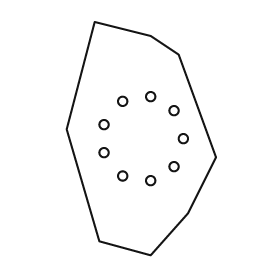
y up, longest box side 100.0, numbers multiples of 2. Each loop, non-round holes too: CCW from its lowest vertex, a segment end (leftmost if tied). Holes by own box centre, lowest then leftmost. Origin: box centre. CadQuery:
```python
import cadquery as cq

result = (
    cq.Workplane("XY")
    .moveTo(4.0, -50.0)
    .lineTo(20.0, -32.0)
    .lineTo(32.0, -8.0)
    .lineTo(16.0, 36.0)
    .lineTo(4.0, 44.0)
    .lineTo(-20.0, 50.0)
    .lineTo(-32.0, 4.0)
    .lineTo(-18.0, -44.0)
    .close()
    .moveTo(4.0, -18.0)
    .circle(2.0)
    .moveTo(-8.0, -16.0)
    .circle(2.0)
    .moveTo(14.0, -12.0)
    .circle(2.0)
    .moveTo(-16.0, -6.0)
    .circle(2.0)
    .moveTo(18.0, 0.0)
    .circle(2.0)
    .moveTo(-16.0, 6.0)
    .circle(2.0)
    .moveTo(14.0, 12.0)
    .circle(2.0)
    .moveTo(-8.0, 16.0)
    .circle(2.0)
    .moveTo(4.0, 18.0)
    .circle(2.0)
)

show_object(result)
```